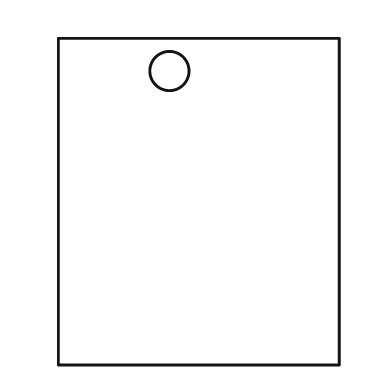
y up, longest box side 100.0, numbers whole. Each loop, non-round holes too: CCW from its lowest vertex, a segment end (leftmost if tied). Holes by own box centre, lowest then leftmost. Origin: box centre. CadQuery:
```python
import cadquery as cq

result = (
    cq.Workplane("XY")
    .moveTo(-43.0, -50.0)
    .lineTo(43.0, -50.0)
    .lineTo(43.0, 50.0)
    .lineTo(-43.0, 50.0)
    .close()
    .moveTo(-9.0, 40.0)
    .circle(6.0)
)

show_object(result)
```